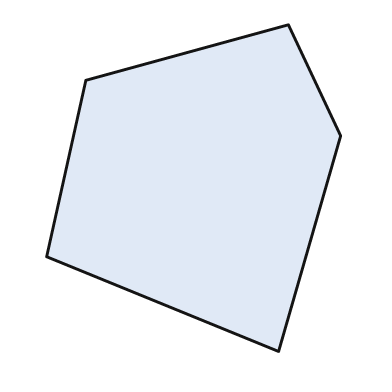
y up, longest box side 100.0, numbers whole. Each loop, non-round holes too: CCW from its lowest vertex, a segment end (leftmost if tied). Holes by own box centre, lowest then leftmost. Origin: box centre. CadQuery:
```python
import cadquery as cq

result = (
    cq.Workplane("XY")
    .moveTo(26.0, -50.0)
    .lineTo(45.0, 16.0)
    .lineTo(29.0, 50.0)
    .lineTo(-33.0, 33.0)
    .lineTo(-45.0, -21.0)
    .close()
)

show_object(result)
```